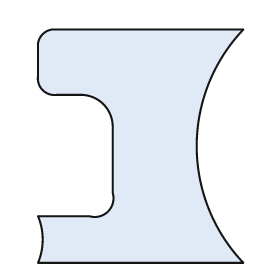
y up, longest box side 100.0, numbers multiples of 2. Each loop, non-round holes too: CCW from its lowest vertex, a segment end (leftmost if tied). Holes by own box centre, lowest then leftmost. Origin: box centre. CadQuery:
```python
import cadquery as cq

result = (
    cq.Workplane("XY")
    .moveTo(-44.0, -50.0)
    .lineTo(44.0, -50.0)
    .threePointArc((24.0, 0.0), (44.0, 50.0))
    .lineTo(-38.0, 50.0)
    .threePointArc((-42.0, 48.0), (-44.0, 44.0))
    .lineTo(-44.0, 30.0)
    .threePointArc((-42.0, 24.0), (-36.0, 22.0))
    .lineTo(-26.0, 22.0)
    .threePointArc((-16.0, 18.0), (-12.0, 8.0))
    .lineTo(-12.0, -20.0)
    .threePointArc((-14.0, -28.0), (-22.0, -30.0))
    .lineTo(-44.0, -30.0)
    .threePointArc((-42.0, -40.0), (-44.0, -50.0))
    .close()
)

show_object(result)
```